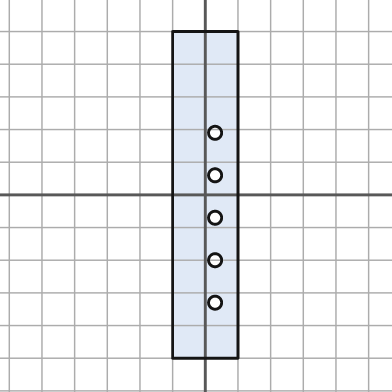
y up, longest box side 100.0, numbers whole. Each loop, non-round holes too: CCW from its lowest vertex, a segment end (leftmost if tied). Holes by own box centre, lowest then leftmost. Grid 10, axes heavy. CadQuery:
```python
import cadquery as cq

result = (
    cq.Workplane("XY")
    .moveTo(-10.0, -50.0)
    .lineTo(10.0, -50.0)
    .lineTo(10.0, 50.0)
    .lineTo(-10.0, 50.0)
    .close()
    .moveTo(3.0, -33.0)
    .circle(2.0)
    .moveTo(3.0, -20.0)
    .circle(2.0)
    .moveTo(3.0, -7.0)
    .circle(2.0)
    .moveTo(3.0, 6.0)
    .circle(2.0)
    .moveTo(3.0, 19.0)
    .circle(2.0)
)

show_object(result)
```